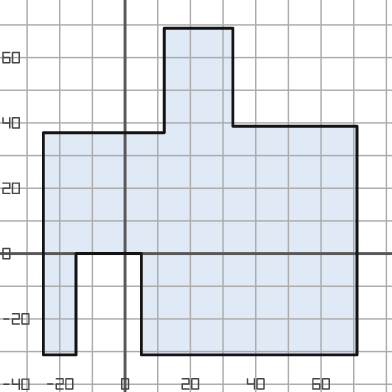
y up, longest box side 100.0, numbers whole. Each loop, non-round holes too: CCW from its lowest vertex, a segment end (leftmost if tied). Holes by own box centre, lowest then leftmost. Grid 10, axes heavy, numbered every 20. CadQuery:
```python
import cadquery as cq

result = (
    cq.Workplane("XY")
    .moveTo(-25.0, -31.0)
    .lineTo(-15.0, -31.0)
    .lineTo(-15.0, 0.0)
    .lineTo(5.0, 0.0)
    .lineTo(5.0, -31.0)
    .lineTo(71.0, -31.0)
    .lineTo(71.0, 39.0)
    .lineTo(33.0, 39.0)
    .lineTo(33.0, 69.0)
    .lineTo(12.0, 69.0)
    .lineTo(12.0, 37.0)
    .lineTo(-25.0, 37.0)
    .close()
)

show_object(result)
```